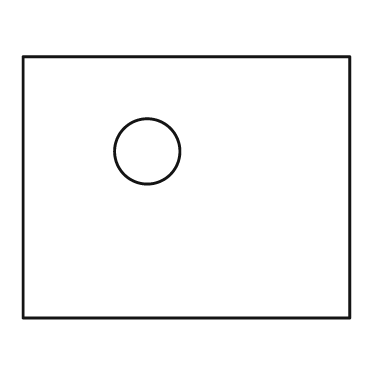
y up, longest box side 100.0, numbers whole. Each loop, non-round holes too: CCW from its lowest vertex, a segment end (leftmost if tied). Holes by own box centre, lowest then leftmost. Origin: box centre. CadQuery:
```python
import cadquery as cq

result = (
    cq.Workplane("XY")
    .moveTo(-50.0, -40.0)
    .lineTo(50.0, -40.0)
    .lineTo(50.0, 40.0)
    .lineTo(-50.0, 40.0)
    .close()
    .moveTo(-12.0, 11.0)
    .circle(10.0)
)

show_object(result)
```